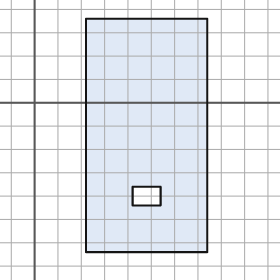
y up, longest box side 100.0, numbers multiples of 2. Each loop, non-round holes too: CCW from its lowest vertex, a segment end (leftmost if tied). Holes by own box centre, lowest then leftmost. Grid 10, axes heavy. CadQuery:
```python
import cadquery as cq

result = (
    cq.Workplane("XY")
    .moveTo(22.0, -64.0)
    .lineTo(74.0, -64.0)
    .lineTo(74.0, 36.0)
    .lineTo(22.0, 36.0)
    .close()
    .moveTo(42.0, -44.0)
    .lineTo(54.0, -44.0)
    .lineTo(54.0, -36.0)
    .lineTo(42.0, -36.0)
    .close()
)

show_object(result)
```